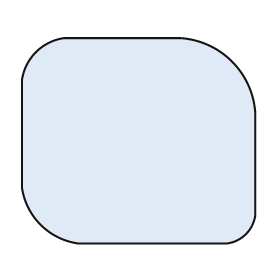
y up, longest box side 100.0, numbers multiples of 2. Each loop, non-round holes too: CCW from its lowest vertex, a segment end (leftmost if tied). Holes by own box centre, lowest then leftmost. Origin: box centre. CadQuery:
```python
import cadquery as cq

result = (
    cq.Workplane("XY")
    .moveTo(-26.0, -44.0)
    .lineTo(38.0, -44.0)
    .threePointArc((46.0, -40.0), (50.0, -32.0))
    .lineTo(50.0, 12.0)
    .threePointArc((40.0, 34.0), (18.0, 44.0))
    .lineTo(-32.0, 44.0)
    .threePointArc((-44.0, 38.0), (-50.0, 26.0))
    .lineTo(-50.0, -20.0)
    .threePointArc((-42.0, -36.0), (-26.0, -44.0))
    .close()
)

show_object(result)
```